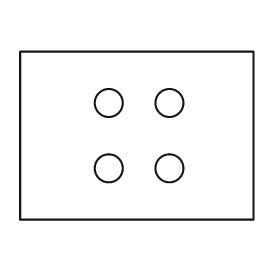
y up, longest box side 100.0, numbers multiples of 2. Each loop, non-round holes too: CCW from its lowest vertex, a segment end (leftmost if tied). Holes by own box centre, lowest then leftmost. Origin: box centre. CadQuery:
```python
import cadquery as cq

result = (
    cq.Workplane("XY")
    .moveTo(-50.0, -36.0)
    .lineTo(50.0, -36.0)
    .lineTo(50.0, 36.0)
    .lineTo(-50.0, 36.0)
    .close()
    .moveTo(-12.0, -14.0)
    .circle(6.0)
    .moveTo(14.0, -14.0)
    .circle(6.0)
    .moveTo(-12.0, 14.0)
    .circle(6.0)
    .moveTo(14.0, 14.0)
    .circle(6.0)
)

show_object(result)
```